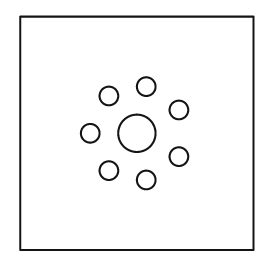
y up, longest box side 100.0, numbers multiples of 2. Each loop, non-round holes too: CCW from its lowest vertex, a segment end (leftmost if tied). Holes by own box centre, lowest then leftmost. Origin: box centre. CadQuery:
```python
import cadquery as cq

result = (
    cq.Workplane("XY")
    .moveTo(-50.0, -50.0)
    .lineTo(50.0, -50.0)
    .lineTo(50.0, 50.0)
    .lineTo(-50.0, 50.0)
    .close()
    .moveTo(4.0, -20.0)
    .circle(4.0)
    .moveTo(-12.0, -16.0)
    .circle(4.0)
    .moveTo(18.0, -10.0)
    .circle(4.0)
    .moveTo(-20.0, 0.0)
    .circle(4.0)
    .moveTo(0.0, 0.0)
    .circle(8.0)
    .moveTo(18.0, 10.0)
    .circle(4.0)
    .moveTo(-12.0, 16.0)
    .circle(4.0)
    .moveTo(4.0, 20.0)
    .circle(4.0)
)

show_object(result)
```